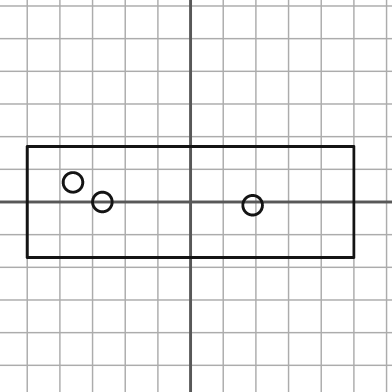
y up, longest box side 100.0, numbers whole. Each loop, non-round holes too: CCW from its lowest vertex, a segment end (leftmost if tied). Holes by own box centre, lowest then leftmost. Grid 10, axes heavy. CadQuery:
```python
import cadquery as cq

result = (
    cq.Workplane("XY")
    .moveTo(-50.0, -17.0)
    .lineTo(50.0, -17.0)
    .lineTo(50.0, 17.0)
    .lineTo(-50.0, 17.0)
    .close()
    .moveTo(19.0, -1.0)
    .circle(3.0)
    .moveTo(-27.0, 0.0)
    .circle(3.0)
    .moveTo(-36.0, 6.0)
    .circle(3.0)
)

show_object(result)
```